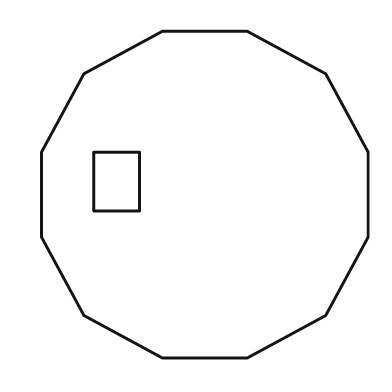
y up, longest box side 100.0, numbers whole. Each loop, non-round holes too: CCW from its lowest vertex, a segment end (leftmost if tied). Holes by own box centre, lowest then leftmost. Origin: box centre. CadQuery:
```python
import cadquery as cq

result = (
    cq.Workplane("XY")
    .moveTo(-13.0, -50.0)
    .lineTo(13.0, -50.0)
    .lineTo(37.0, -37.0)
    .lineTo(50.0, -13.0)
    .lineTo(50.0, 13.0)
    .lineTo(37.0, 37.0)
    .lineTo(13.0, 50.0)
    .lineTo(-13.0, 50.0)
    .lineTo(-37.0, 37.0)
    .lineTo(-50.0, 13.0)
    .lineTo(-50.0, -13.0)
    .lineTo(-37.0, -37.0)
    .close()
    .moveTo(-34.0, -5.0)
    .lineTo(-20.0, -5.0)
    .lineTo(-20.0, 13.0)
    .lineTo(-34.0, 13.0)
    .close()
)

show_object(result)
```